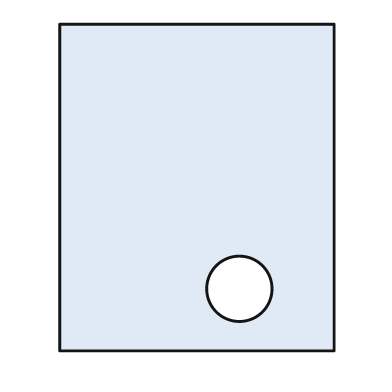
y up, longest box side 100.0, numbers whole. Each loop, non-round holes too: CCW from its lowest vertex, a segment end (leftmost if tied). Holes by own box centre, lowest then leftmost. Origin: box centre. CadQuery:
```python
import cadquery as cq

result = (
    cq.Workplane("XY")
    .moveTo(-42.0, -50.0)
    .lineTo(42.0, -50.0)
    .lineTo(42.0, 50.0)
    .lineTo(-42.0, 50.0)
    .close()
    .moveTo(13.0, -31.0)
    .circle(10.0)
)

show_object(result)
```